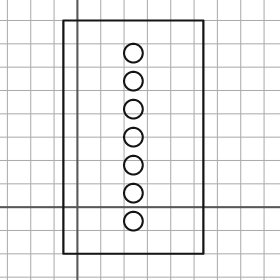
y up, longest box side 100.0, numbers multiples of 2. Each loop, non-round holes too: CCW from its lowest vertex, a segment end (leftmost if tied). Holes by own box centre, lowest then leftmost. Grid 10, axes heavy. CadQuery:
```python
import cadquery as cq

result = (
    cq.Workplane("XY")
    .moveTo(-6.0, -20.0)
    .lineTo(54.0, -20.0)
    .lineTo(54.0, 80.0)
    .lineTo(-6.0, 80.0)
    .close()
    .moveTo(24.0, -6.0)
    .circle(4.0)
    .moveTo(24.0, 6.0)
    .circle(4.0)
    .moveTo(24.0, 18.0)
    .circle(4.0)
    .moveTo(24.0, 30.0)
    .circle(4.0)
    .moveTo(24.0, 42.0)
    .circle(4.0)
    .moveTo(24.0, 54.0)
    .circle(4.0)
    .moveTo(24.0, 66.0)
    .circle(4.0)
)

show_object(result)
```